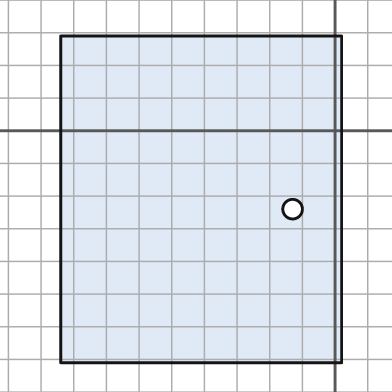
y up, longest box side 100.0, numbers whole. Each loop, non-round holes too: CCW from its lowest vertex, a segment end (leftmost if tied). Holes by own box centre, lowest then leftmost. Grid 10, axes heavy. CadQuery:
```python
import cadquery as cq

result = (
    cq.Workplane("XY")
    .moveTo(-84.0, -71.0)
    .lineTo(2.0, -71.0)
    .lineTo(2.0, 29.0)
    .lineTo(-84.0, 29.0)
    .close()
    .moveTo(-13.0, -24.0)
    .circle(3.0)
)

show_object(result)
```